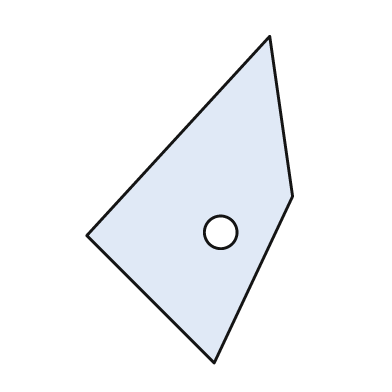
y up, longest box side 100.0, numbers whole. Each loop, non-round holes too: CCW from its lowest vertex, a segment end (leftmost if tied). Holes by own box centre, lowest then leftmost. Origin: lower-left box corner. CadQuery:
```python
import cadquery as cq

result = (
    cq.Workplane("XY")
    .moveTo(39.0, 0.0)
    .lineTo(63.0, 51.0)
    .lineTo(56.0, 100.0)
    .lineTo(0.0, 39.0)
    .close()
    .moveTo(41.0, 40.0)
    .circle(5.0)
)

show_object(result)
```